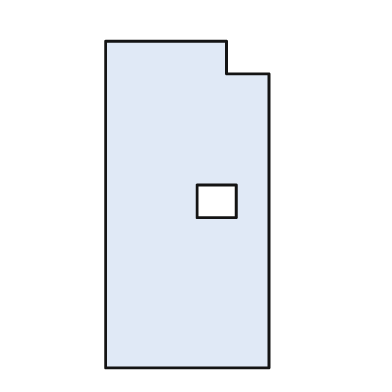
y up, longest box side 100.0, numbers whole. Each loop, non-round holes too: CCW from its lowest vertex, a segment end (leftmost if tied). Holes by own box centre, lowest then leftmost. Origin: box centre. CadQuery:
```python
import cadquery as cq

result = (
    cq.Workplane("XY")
    .moveTo(-25.0, -50.0)
    .lineTo(25.0, -50.0)
    .lineTo(25.0, 40.0)
    .lineTo(12.0, 40.0)
    .lineTo(12.0, 50.0)
    .lineTo(-25.0, 50.0)
    .close()
    .moveTo(3.0, -4.0)
    .lineTo(15.0, -4.0)
    .lineTo(15.0, 6.0)
    .lineTo(3.0, 6.0)
    .close()
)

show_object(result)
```